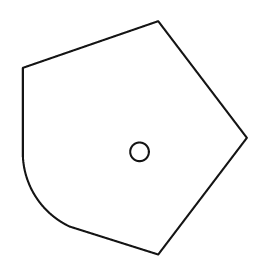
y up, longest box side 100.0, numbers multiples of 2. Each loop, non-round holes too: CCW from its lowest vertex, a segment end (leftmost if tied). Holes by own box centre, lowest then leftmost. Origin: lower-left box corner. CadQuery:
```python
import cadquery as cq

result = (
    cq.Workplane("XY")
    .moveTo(58.0, 0.0)
    .lineTo(96.0, 50.0)
    .lineTo(58.0, 100.0)
    .lineTo(0.0, 80.0)
    .lineTo(0.0, 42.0)
    .threePointArc((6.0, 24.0), (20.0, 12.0))
    .close()
    .moveTo(50.0, 44.0)
    .circle(4.0)
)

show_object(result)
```